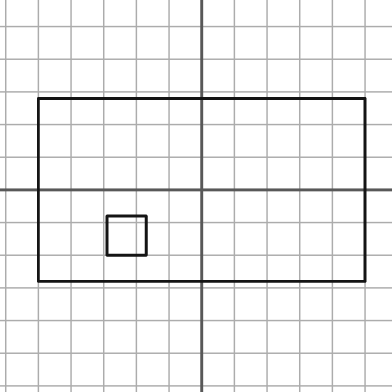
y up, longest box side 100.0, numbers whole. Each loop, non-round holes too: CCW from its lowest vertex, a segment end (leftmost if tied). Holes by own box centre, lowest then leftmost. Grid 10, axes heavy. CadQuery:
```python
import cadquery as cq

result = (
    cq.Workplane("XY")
    .moveTo(-50.0, -28.0)
    .lineTo(50.0, -28.0)
    .lineTo(50.0, 28.0)
    .lineTo(-50.0, 28.0)
    .close()
    .moveTo(-29.0, -20.0)
    .lineTo(-17.0, -20.0)
    .lineTo(-17.0, -8.0)
    .lineTo(-29.0, -8.0)
    .close()
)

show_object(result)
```